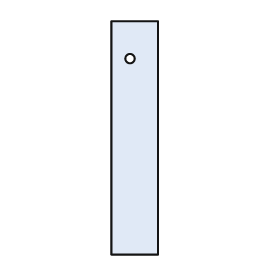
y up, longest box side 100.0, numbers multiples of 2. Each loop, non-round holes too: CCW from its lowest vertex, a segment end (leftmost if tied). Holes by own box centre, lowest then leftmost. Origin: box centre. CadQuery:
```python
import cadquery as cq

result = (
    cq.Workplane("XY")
    .moveTo(-10.0, -50.0)
    .lineTo(10.0, -50.0)
    .lineTo(10.0, 50.0)
    .lineTo(-10.0, 50.0)
    .close()
    .moveTo(-2.0, 34.0)
    .circle(2.0)
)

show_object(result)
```